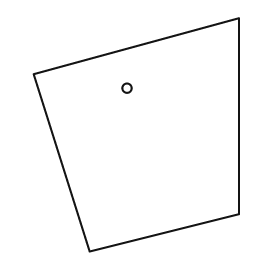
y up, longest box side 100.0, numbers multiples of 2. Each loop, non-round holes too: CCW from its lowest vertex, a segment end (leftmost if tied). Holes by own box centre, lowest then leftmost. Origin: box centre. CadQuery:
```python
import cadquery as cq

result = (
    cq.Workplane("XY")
    .moveTo(-20.0, -50.0)
    .lineTo(44.0, -34.0)
    .lineTo(44.0, 50.0)
    .lineTo(-44.0, 26.0)
    .close()
    .moveTo(-4.0, 20.0)
    .circle(2.0)
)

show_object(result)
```